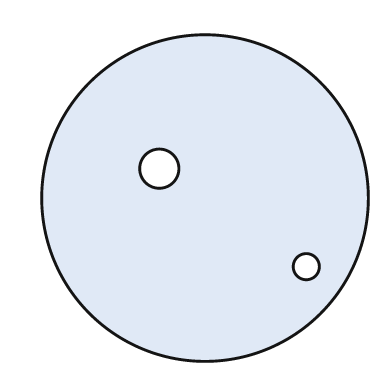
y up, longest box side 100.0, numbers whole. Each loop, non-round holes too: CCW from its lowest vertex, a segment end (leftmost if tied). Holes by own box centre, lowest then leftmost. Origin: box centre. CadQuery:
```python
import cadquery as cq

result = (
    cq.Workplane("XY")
    .moveTo(0.0, 0.0)
    .circle(50.0)
    .moveTo(31.0, -21.0)
    .circle(4.0)
    .moveTo(-14.0, 9.0)
    .circle(6.0)
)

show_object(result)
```